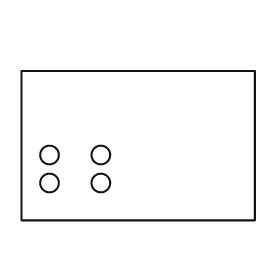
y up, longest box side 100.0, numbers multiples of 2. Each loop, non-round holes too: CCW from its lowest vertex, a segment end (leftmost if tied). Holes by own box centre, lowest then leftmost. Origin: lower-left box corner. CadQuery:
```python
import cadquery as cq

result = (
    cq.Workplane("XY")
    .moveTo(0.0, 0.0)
    .lineTo(100.0, 0.0)
    .lineTo(100.0, 64.0)
    .lineTo(0.0, 64.0)
    .close()
    .moveTo(12.0, 16.0)
    .circle(4.0)
    .moveTo(34.0, 16.0)
    .circle(4.0)
    .moveTo(12.0, 28.0)
    .circle(4.0)
    .moveTo(34.0, 28.0)
    .circle(4.0)
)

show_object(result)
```